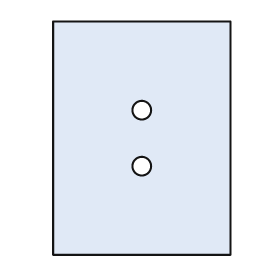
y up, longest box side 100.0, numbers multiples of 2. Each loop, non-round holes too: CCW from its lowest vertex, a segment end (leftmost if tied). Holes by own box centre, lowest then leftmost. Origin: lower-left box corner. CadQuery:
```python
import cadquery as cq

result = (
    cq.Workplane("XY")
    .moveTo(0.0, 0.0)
    .lineTo(76.0, 0.0)
    .lineTo(76.0, 100.0)
    .lineTo(0.0, 100.0)
    .close()
    .moveTo(38.0, 38.0)
    .circle(4.0)
    .moveTo(38.0, 62.0)
    .circle(4.0)
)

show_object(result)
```